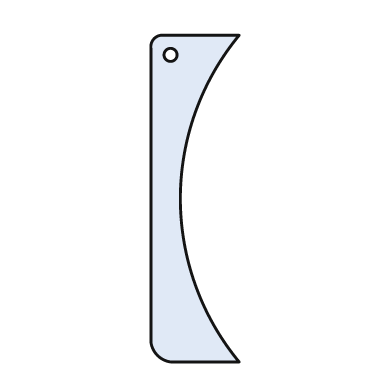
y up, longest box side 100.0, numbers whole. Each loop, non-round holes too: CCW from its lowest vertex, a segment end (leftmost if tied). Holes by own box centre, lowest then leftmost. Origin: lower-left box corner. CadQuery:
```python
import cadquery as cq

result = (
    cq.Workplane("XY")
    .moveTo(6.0, 0.0)
    .lineTo(27.0, 0.0)
    .threePointArc((9.0, 50.0), (27.0, 100.0))
    .lineTo(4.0, 100.0)
    .threePointArc((1.0, 99.0), (0.0, 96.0))
    .lineTo(0.0, 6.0)
    .threePointArc((2.0, 2.0), (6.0, 0.0))
    .close()
    .moveTo(6.0, 94.0)
    .circle(2.0)
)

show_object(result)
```